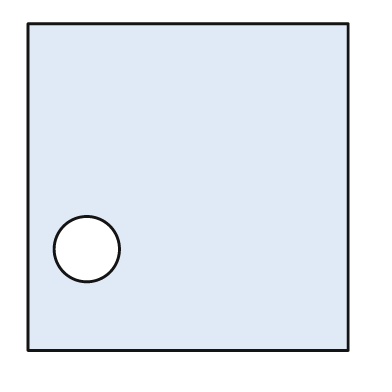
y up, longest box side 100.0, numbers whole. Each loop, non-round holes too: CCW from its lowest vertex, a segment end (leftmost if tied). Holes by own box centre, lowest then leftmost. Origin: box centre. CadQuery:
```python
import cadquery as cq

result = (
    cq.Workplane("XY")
    .moveTo(-49.0, -50.0)
    .lineTo(49.0, -50.0)
    .lineTo(49.0, 50.0)
    .lineTo(-49.0, 50.0)
    .close()
    .moveTo(-31.0, -19.0)
    .circle(10.0)
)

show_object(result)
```